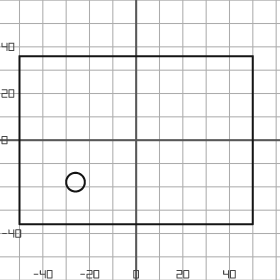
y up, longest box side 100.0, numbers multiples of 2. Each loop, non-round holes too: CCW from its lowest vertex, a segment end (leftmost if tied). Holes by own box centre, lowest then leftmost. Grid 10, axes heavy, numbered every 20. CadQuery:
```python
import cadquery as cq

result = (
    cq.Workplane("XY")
    .moveTo(-50.0, -36.0)
    .lineTo(50.0, -36.0)
    .lineTo(50.0, 36.0)
    .lineTo(-50.0, 36.0)
    .close()
    .moveTo(-26.0, -18.0)
    .circle(4.0)
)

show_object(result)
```